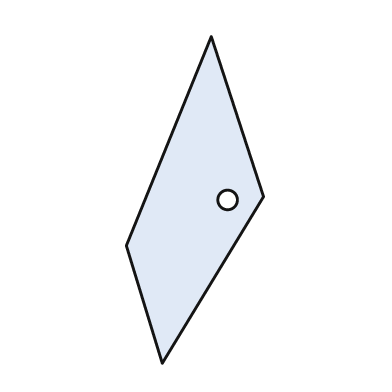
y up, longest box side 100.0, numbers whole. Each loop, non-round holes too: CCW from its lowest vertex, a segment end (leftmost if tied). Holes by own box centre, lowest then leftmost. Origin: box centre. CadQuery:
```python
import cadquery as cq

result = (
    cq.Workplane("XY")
    .moveTo(-10.0, -50.0)
    .lineTo(21.0, 1.0)
    .lineTo(5.0, 50.0)
    .lineTo(-21.0, -14.0)
    .close()
    .moveTo(10.0, 0.0)
    .circle(3.0)
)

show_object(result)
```